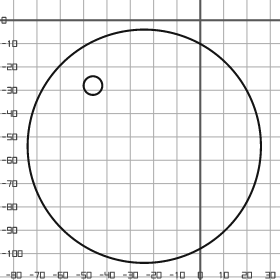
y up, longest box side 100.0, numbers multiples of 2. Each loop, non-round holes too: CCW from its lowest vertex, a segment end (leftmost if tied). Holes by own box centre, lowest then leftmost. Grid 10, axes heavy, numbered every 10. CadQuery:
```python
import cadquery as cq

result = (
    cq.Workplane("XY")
    .moveTo(-24.0, -54.0)
    .circle(50.0)
    .moveTo(-46.0, -28.0)
    .circle(4.0)
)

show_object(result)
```